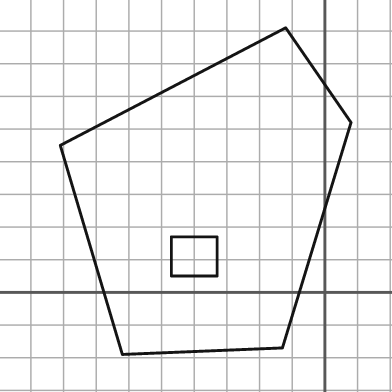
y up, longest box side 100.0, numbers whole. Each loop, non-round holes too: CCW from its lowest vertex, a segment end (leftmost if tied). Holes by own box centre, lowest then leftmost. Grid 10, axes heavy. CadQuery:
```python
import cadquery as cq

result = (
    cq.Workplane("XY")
    .moveTo(-62.0, -19.0)
    .lineTo(-13.0, -17.0)
    .lineTo(8.0, 52.0)
    .lineTo(-12.0, 81.0)
    .lineTo(-81.0, 45.0)
    .close()
    .moveTo(-47.0, 5.0)
    .lineTo(-33.0, 5.0)
    .lineTo(-33.0, 17.0)
    .lineTo(-47.0, 17.0)
    .close()
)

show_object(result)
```